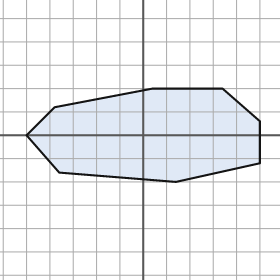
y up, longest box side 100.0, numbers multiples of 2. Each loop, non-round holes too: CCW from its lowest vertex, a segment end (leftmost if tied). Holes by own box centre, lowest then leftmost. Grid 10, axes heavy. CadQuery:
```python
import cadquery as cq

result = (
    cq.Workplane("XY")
    .moveTo(14.0, -20.0)
    .lineTo(50.0, -12.0)
    .lineTo(50.0, 6.0)
    .lineTo(34.0, 20.0)
    .lineTo(4.0, 20.0)
    .lineTo(-38.0, 12.0)
    .lineTo(-50.0, 0.0)
    .lineTo(-36.0, -16.0)
    .close()
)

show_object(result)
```